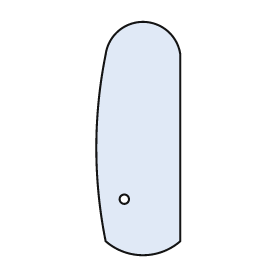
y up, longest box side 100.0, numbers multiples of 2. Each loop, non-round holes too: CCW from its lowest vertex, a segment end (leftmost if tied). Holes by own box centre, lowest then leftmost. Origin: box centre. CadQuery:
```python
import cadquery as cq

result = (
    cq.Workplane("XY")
    .moveTo(-14.0, -44.0)
    .threePointArc((2.0, -50.0), (18.0, -44.0))
    .lineTo(18.0, 36.0)
    .threePointArc((2.0, 50.0), (-14.0, 36.0))
    .threePointArc((-18.0, -4.0), (-14.0, -44.0))
    .close()
    .moveTo(-6.0, -26.0)
    .circle(2.0)
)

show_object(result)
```